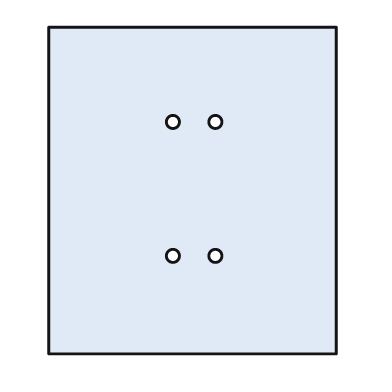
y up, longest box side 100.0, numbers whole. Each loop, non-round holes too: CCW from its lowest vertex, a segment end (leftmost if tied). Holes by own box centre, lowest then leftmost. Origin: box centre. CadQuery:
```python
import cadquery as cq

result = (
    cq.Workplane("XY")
    .moveTo(-44.0, -50.0)
    .lineTo(44.0, -50.0)
    .lineTo(44.0, 50.0)
    .lineTo(-44.0, 50.0)
    .close()
    .moveTo(-6.0, -20.0)
    .circle(2.0)
    .moveTo(7.0, -20.0)
    .circle(2.0)
    .moveTo(-6.0, 21.0)
    .circle(2.0)
    .moveTo(7.0, 21.0)
    .circle(2.0)
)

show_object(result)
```